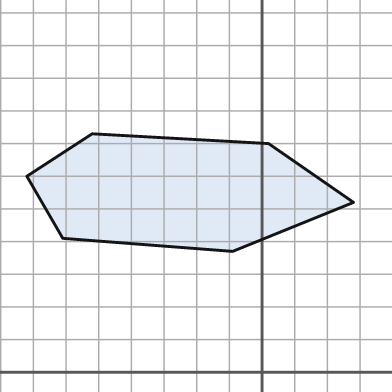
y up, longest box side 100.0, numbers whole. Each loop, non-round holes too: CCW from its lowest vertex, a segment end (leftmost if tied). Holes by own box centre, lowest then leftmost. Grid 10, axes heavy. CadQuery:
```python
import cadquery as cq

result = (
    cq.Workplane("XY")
    .moveTo(-9.0, 37.0)
    .lineTo(28.0, 52.0)
    .lineTo(2.0, 70.0)
    .lineTo(-52.0, 73.0)
    .lineTo(-72.0, 60.0)
    .lineTo(-61.0, 41.0)
    .close()
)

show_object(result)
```